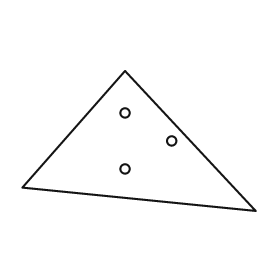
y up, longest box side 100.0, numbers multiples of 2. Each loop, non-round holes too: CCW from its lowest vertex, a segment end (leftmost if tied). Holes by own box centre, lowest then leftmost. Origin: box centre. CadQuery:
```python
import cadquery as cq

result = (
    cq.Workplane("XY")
    .moveTo(50.0, -30.0)
    .lineTo(-6.0, 30.0)
    .lineTo(-50.0, -20.0)
    .close()
    .moveTo(-6.0, -12.0)
    .circle(2.0)
    .moveTo(14.0, 0.0)
    .circle(2.0)
    .moveTo(-6.0, 12.0)
    .circle(2.0)
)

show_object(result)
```